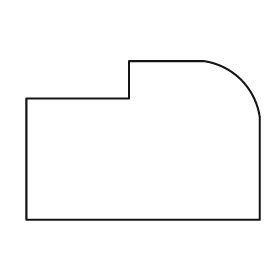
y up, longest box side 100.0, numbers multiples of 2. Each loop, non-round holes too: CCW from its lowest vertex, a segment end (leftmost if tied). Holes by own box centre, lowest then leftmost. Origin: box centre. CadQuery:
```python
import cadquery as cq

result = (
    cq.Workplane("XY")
    .moveTo(-50.0, -34.0)
    .lineTo(50.0, -34.0)
    .lineTo(50.0, 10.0)
    .threePointArc((42.0, 26.0), (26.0, 34.0))
    .lineTo(-6.0, 34.0)
    .lineTo(-6.0, 18.0)
    .lineTo(-50.0, 18.0)
    .close()
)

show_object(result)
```